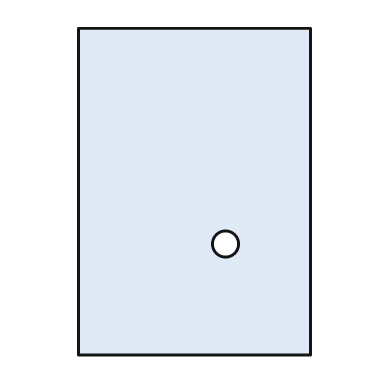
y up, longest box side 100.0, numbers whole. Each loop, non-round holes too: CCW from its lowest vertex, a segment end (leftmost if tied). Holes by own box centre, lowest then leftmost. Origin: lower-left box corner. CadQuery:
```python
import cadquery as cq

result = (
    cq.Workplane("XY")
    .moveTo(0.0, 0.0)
    .lineTo(71.0, 0.0)
    .lineTo(71.0, 100.0)
    .lineTo(0.0, 100.0)
    .close()
    .moveTo(45.0, 34.0)
    .circle(4.0)
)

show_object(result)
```